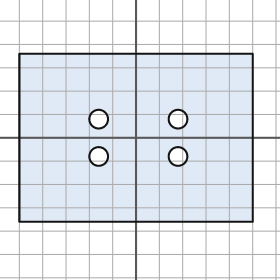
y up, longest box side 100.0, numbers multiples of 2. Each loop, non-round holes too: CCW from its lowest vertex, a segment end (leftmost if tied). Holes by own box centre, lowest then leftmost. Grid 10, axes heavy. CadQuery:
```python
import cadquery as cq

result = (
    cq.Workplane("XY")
    .moveTo(-50.0, -36.0)
    .lineTo(50.0, -36.0)
    .lineTo(50.0, 36.0)
    .lineTo(-50.0, 36.0)
    .close()
    .moveTo(-16.0, -8.0)
    .circle(4.0)
    .moveTo(18.0, -8.0)
    .circle(4.0)
    .moveTo(-16.0, 8.0)
    .circle(4.0)
    .moveTo(18.0, 8.0)
    .circle(4.0)
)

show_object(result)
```